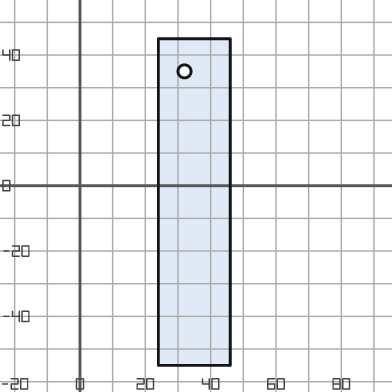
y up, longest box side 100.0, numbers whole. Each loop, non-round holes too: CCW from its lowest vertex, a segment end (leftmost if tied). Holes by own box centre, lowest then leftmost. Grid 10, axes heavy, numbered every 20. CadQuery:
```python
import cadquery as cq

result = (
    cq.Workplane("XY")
    .moveTo(24.0, -55.0)
    .lineTo(46.0, -55.0)
    .lineTo(46.0, 45.0)
    .lineTo(24.0, 45.0)
    .close()
    .moveTo(32.0, 35.0)
    .circle(2.0)
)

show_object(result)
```